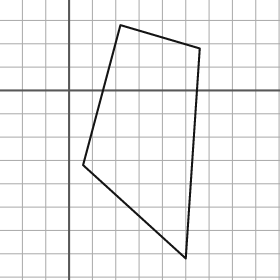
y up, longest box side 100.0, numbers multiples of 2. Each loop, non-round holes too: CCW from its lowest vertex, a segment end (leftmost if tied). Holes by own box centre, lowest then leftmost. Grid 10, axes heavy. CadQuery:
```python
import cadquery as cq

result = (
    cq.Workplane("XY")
    .moveTo(50.0, -72.0)
    .lineTo(56.0, 18.0)
    .lineTo(22.0, 28.0)
    .lineTo(6.0, -32.0)
    .close()
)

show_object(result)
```